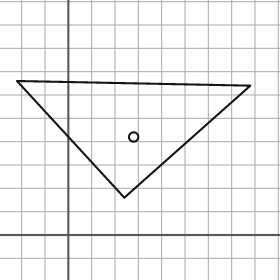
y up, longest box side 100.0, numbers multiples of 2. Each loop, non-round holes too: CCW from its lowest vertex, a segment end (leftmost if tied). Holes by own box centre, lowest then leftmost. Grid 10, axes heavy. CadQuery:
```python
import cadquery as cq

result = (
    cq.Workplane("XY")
    .moveTo(24.0, 16.0)
    .lineTo(78.0, 64.0)
    .lineTo(-22.0, 66.0)
    .close()
    .moveTo(28.0, 42.0)
    .circle(2.0)
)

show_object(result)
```